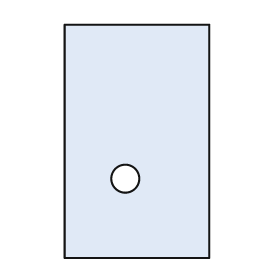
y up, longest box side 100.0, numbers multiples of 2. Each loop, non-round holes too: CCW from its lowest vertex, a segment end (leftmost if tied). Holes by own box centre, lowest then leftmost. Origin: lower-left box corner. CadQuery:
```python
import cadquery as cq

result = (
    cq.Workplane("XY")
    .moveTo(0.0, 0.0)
    .lineTo(62.0, 0.0)
    .lineTo(62.0, 100.0)
    .lineTo(0.0, 100.0)
    .close()
    .moveTo(26.0, 34.0)
    .circle(6.0)
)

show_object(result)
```